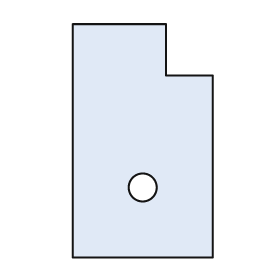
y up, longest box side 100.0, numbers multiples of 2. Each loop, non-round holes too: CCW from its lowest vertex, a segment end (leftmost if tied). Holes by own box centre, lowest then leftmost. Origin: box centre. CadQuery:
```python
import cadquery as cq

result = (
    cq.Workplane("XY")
    .moveTo(-30.0, -50.0)
    .lineTo(30.0, -50.0)
    .lineTo(30.0, 28.0)
    .lineTo(10.0, 28.0)
    .lineTo(10.0, 50.0)
    .lineTo(-30.0, 50.0)
    .close()
    .moveTo(0.0, -20.0)
    .circle(6.0)
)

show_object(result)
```